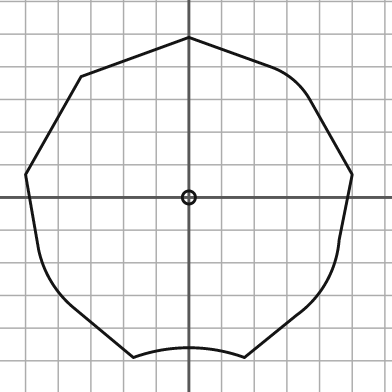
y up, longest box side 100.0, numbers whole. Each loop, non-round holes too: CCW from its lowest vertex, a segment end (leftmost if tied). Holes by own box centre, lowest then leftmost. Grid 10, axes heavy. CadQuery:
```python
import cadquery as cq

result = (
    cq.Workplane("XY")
    .moveTo(-17.0, -49.0)
    .threePointArc((0.0, -46.0), (17.0, -49.0))
    .lineTo(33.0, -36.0)
    .threePointArc((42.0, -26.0), (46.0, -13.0))
    .lineTo(50.0, 7.0)
    .lineTo(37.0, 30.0)
    .threePointArc((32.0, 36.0), (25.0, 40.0))
    .lineTo(0.0, 49.0)
    .lineTo(-33.0, 37.0)
    .lineTo(-50.0, 7.0)
    .lineTo(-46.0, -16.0)
    .threePointArc((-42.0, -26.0), (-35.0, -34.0))
    .close()
    .moveTo(0.0, 0.0)
    .circle(2.0)
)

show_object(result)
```